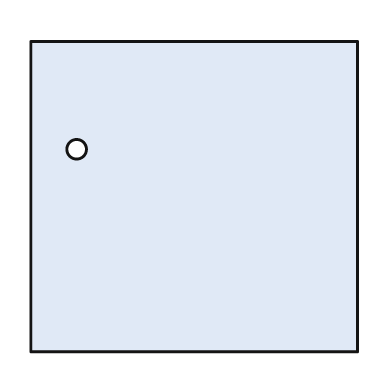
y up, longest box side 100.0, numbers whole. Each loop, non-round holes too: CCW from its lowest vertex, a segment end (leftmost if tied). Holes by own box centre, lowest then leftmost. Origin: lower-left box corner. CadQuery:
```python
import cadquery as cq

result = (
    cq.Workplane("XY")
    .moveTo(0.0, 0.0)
    .lineTo(100.0, 0.0)
    .lineTo(100.0, 95.0)
    .lineTo(0.0, 95.0)
    .close()
    .moveTo(14.0, 62.0)
    .circle(3.0)
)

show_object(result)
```